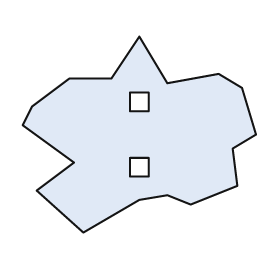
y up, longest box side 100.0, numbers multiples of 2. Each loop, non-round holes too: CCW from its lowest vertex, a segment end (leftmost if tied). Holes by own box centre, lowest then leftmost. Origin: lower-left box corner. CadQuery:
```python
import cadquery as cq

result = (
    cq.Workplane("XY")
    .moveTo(26.0, 0.0)
    .lineTo(50.0, 14.0)
    .lineTo(62.0, 16.0)
    .lineTo(72.0, 12.0)
    .lineTo(92.0, 20.0)
    .lineTo(90.0, 36.0)
    .lineTo(100.0, 42.0)
    .lineTo(94.0, 62.0)
    .lineTo(84.0, 68.0)
    .lineTo(62.0, 64.0)
    .lineTo(50.0, 84.0)
    .lineTo(38.0, 66.0)
    .lineTo(20.0, 66.0)
    .lineTo(4.0, 54.0)
    .lineTo(0.0, 46.0)
    .lineTo(22.0, 30.0)
    .lineTo(6.0, 18.0)
    .close()
    .moveTo(46.0, 24.0)
    .lineTo(54.0, 24.0)
    .lineTo(54.0, 32.0)
    .lineTo(46.0, 32.0)
    .close()
    .moveTo(46.0, 52.0)
    .lineTo(54.0, 52.0)
    .lineTo(54.0, 60.0)
    .lineTo(46.0, 60.0)
    .close()
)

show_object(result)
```